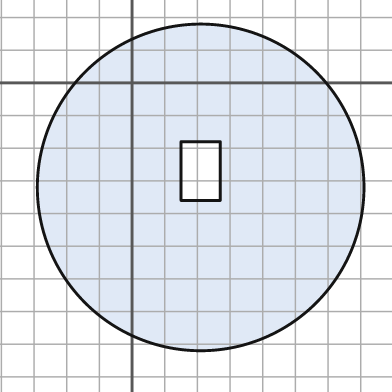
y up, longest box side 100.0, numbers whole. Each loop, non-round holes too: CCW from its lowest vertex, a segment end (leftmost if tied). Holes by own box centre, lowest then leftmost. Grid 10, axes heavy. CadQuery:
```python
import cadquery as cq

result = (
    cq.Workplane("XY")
    .moveTo(21.0, -32.0)
    .circle(50.0)
    .moveTo(15.0, -36.0)
    .lineTo(27.0, -36.0)
    .lineTo(27.0, -18.0)
    .lineTo(15.0, -18.0)
    .close()
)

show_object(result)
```